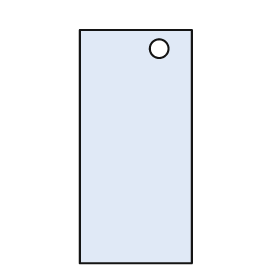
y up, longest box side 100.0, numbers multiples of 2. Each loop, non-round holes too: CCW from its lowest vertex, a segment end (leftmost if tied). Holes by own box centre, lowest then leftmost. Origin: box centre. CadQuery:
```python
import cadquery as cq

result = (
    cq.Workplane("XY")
    .moveTo(-24.0, -50.0)
    .lineTo(24.0, -50.0)
    .lineTo(24.0, 50.0)
    .lineTo(-24.0, 50.0)
    .close()
    .moveTo(10.0, 42.0)
    .circle(4.0)
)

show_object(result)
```